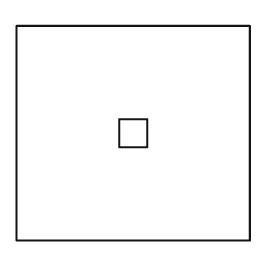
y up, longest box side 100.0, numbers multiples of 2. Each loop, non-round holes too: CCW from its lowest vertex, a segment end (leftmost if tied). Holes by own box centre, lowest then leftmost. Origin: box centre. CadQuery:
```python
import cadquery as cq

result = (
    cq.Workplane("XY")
    .moveTo(-50.0, -46.0)
    .lineTo(50.0, -46.0)
    .lineTo(50.0, 46.0)
    .lineTo(-50.0, 46.0)
    .close()
    .moveTo(-6.0, -6.0)
    .lineTo(6.0, -6.0)
    .lineTo(6.0, 6.0)
    .lineTo(-6.0, 6.0)
    .close()
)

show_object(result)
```